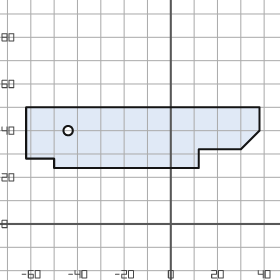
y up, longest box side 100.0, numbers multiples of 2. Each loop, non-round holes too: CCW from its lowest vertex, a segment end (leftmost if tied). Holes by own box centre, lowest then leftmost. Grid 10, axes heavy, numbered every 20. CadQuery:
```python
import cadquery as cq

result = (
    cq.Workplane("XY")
    .moveTo(-50.0, 24.0)
    .lineTo(12.0, 24.0)
    .lineTo(12.0, 32.0)
    .lineTo(30.0, 32.0)
    .lineTo(38.0, 40.0)
    .lineTo(38.0, 50.0)
    .lineTo(-62.0, 50.0)
    .lineTo(-62.0, 28.0)
    .lineTo(-50.0, 28.0)
    .close()
    .moveTo(-44.0, 40.0)
    .circle(2.0)
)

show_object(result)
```